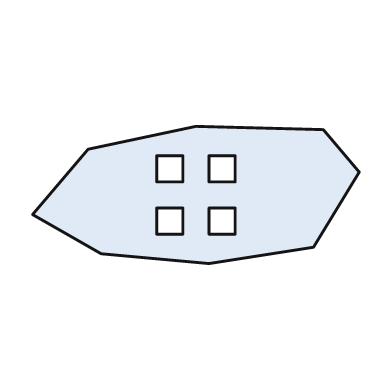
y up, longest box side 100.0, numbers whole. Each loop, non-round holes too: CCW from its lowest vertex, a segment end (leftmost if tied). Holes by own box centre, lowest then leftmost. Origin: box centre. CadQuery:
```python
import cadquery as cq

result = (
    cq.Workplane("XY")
    .moveTo(4.0, -21.0)
    .lineTo(36.0, -16.0)
    .lineTo(50.0, 7.0)
    .lineTo(39.0, 20.0)
    .lineTo(0.0, 21.0)
    .lineTo(-33.0, 14.0)
    .lineTo(-50.0, -6.0)
    .lineTo(-29.0, -18.0)
    .close()
    .moveTo(-12.0, -12.0)
    .lineTo(-4.0, -12.0)
    .lineTo(-4.0, -4.0)
    .lineTo(-12.0, -4.0)
    .close()
    .moveTo(4.0, -12.0)
    .lineTo(12.0, -12.0)
    .lineTo(12.0, -4.0)
    .lineTo(4.0, -4.0)
    .close()
    .moveTo(-12.0, 4.0)
    .lineTo(-4.0, 4.0)
    .lineTo(-4.0, 12.0)
    .lineTo(-12.0, 12.0)
    .close()
    .moveTo(4.0, 4.0)
    .lineTo(12.0, 4.0)
    .lineTo(12.0, 12.0)
    .lineTo(4.0, 12.0)
    .close()
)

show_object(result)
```